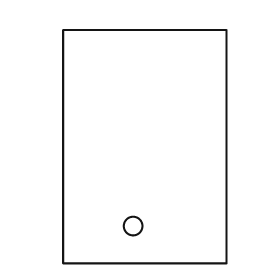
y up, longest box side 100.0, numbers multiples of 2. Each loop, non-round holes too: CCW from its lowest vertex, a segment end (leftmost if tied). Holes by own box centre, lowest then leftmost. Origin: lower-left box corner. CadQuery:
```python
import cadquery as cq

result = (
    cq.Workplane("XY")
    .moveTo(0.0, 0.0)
    .lineTo(70.0, 0.0)
    .lineTo(70.0, 100.0)
    .lineTo(0.0, 100.0)
    .close()
    .moveTo(30.0, 16.0)
    .circle(4.0)
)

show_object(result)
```